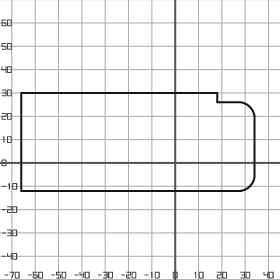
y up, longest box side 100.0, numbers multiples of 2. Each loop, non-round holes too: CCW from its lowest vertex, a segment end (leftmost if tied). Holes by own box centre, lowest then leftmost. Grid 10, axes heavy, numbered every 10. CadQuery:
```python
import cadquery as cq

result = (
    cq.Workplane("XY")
    .moveTo(-66.0, -12.0)
    .lineTo(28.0, -12.0)
    .threePointArc((32.0, -10.0), (34.0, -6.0))
    .lineTo(34.0, 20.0)
    .threePointArc((32.0, 24.0), (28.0, 26.0))
    .lineTo(18.0, 26.0)
    .lineTo(18.0, 30.0)
    .lineTo(-66.0, 30.0)
    .close()
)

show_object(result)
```